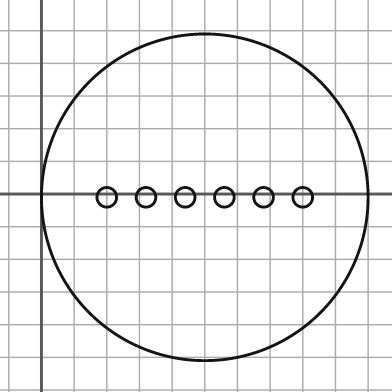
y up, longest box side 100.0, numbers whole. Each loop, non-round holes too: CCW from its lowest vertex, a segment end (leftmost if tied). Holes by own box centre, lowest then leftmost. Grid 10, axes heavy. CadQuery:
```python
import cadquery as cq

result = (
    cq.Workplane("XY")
    .moveTo(50.0, -1.0)
    .circle(50.0)
    .moveTo(20.0, -1.0)
    .circle(3.0)
    .moveTo(32.0, -1.0)
    .circle(3.0)
    .moveTo(44.0, -1.0)
    .circle(3.0)
    .moveTo(56.0, -1.0)
    .circle(3.0)
    .moveTo(68.0, -1.0)
    .circle(3.0)
    .moveTo(80.0, -1.0)
    .circle(3.0)
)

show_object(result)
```